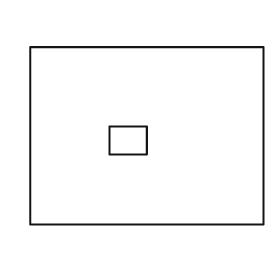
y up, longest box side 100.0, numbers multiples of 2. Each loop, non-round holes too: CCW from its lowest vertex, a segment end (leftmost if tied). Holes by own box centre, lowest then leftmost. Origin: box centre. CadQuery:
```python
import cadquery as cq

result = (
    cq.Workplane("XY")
    .moveTo(-50.0, -38.0)
    .lineTo(50.0, -38.0)
    .lineTo(50.0, 38.0)
    .lineTo(-50.0, 38.0)
    .close()
    .moveTo(-16.0, -8.0)
    .lineTo(0.0, -8.0)
    .lineTo(0.0, 4.0)
    .lineTo(-16.0, 4.0)
    .close()
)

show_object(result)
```